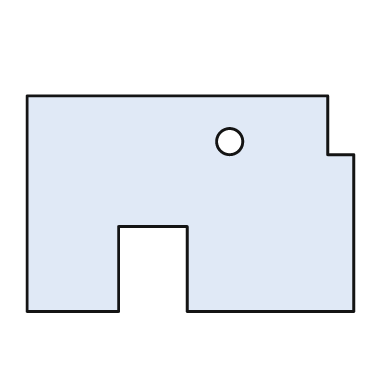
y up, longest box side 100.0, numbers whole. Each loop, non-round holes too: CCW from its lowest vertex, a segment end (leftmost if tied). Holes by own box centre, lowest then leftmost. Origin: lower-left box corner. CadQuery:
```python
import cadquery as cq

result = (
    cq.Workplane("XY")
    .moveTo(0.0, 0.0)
    .lineTo(28.0, 0.0)
    .lineTo(28.0, 26.0)
    .lineTo(49.0, 26.0)
    .lineTo(49.0, 0.0)
    .lineTo(100.0, 0.0)
    .lineTo(100.0, 48.0)
    .lineTo(92.0, 48.0)
    .lineTo(92.0, 66.0)
    .lineTo(0.0, 66.0)
    .close()
    .moveTo(62.0, 52.0)
    .circle(4.0)
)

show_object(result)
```